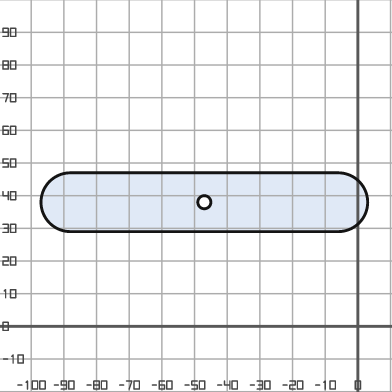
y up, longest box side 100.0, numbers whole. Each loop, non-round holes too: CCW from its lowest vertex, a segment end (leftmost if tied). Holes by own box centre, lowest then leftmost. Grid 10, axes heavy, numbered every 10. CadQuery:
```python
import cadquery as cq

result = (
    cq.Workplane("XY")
    .moveTo(-88.0, 29.0)
    .lineTo(-6.0, 29.0)
    .threePointArc((3.0, 38.0), (-6.0, 47.0))
    .lineTo(-88.0, 47.0)
    .threePointArc((-97.0, 38.0), (-88.0, 29.0))
    .close()
    .moveTo(-47.0, 38.0)
    .circle(2.0)
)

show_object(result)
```